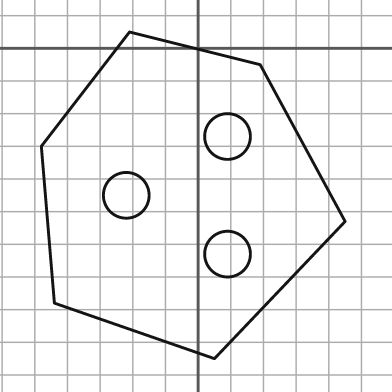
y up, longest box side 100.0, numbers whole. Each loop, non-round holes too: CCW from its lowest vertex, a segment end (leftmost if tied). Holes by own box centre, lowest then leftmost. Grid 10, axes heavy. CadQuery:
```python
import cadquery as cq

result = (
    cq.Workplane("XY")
    .moveTo(5.0, -95.0)
    .lineTo(45.0, -53.0)
    .lineTo(19.0, -5.0)
    .lineTo(-21.0, 5.0)
    .lineTo(-48.0, -30.0)
    .lineTo(-44.0, -78.0)
    .close()
    .moveTo(9.0, -63.0)
    .circle(7.0)
    .moveTo(-22.0, -45.0)
    .circle(7.0)
    .moveTo(9.0, -27.0)
    .circle(7.0)
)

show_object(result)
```